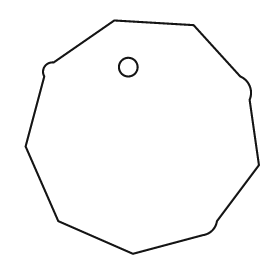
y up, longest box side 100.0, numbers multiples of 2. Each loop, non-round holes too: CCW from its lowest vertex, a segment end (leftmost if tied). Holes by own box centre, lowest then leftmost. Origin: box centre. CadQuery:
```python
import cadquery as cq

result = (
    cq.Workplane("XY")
    .moveTo(-4.0, -50.0)
    .lineTo(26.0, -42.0)
    .threePointArc((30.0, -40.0), (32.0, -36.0))
    .lineTo(50.0, -12.0)
    .lineTo(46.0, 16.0)
    .threePointArc((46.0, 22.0), (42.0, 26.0))
    .lineTo(22.0, 48.0)
    .lineTo(-12.0, 50.0)
    .lineTo(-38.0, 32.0)
    .threePointArc((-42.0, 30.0), (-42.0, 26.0))
    .lineTo(-50.0, -4.0)
    .lineTo(-36.0, -36.0)
    .close()
    .moveTo(-6.0, 30.0)
    .circle(4.0)
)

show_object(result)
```